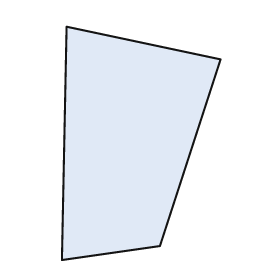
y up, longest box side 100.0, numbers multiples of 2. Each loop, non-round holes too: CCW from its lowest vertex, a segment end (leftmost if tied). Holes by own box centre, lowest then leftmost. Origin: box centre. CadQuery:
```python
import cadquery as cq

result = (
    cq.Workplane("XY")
    .moveTo(-34.0, -50.0)
    .lineTo(8.0, -44.0)
    .lineTo(34.0, 36.0)
    .lineTo(-32.0, 50.0)
    .close()
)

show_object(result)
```